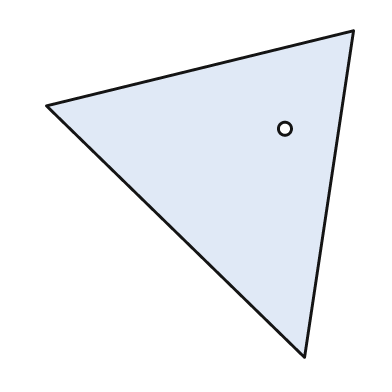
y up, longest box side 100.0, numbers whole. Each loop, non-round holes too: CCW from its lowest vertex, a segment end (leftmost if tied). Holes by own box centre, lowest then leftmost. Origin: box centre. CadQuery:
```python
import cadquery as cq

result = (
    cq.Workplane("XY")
    .moveTo(32.0, -50.0)
    .lineTo(47.0, 50.0)
    .lineTo(-47.0, 27.0)
    .close()
    .moveTo(26.0, 20.0)
    .circle(2.0)
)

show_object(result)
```